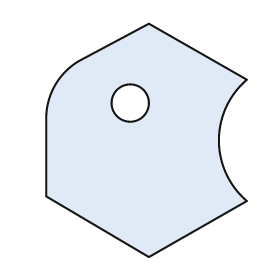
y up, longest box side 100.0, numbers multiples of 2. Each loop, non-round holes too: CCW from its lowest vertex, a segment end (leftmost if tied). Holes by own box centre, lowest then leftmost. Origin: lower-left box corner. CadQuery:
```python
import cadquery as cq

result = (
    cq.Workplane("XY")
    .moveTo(44.0, 0.0)
    .lineTo(86.0, 24.0)
    .threePointArc((74.0, 50.0), (86.0, 76.0))
    .lineTo(44.0, 100.0)
    .lineTo(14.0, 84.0)
    .threePointArc((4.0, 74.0), (0.0, 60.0))
    .lineTo(0.0, 26.0)
    .close()
    .moveTo(36.0, 66.0)
    .circle(8.0)
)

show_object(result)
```